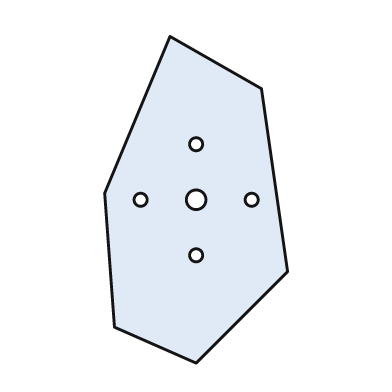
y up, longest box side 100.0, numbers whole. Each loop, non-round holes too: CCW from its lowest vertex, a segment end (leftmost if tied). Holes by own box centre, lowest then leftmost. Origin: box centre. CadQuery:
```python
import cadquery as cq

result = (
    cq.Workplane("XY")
    .moveTo(0.0, -50.0)
    .lineTo(28.0, -22.0)
    .lineTo(20.0, 34.0)
    .lineTo(-8.0, 50.0)
    .lineTo(-28.0, 2.0)
    .lineTo(-25.0, -39.0)
    .close()
    .moveTo(0.0, -17.0)
    .circle(2.0)
    .moveTo(-17.0, 0.0)
    .circle(2.0)
    .moveTo(0.0, 0.0)
    .circle(3.0)
    .moveTo(17.0, 0.0)
    .circle(2.0)
    .moveTo(0.0, 17.0)
    .circle(2.0)
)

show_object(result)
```